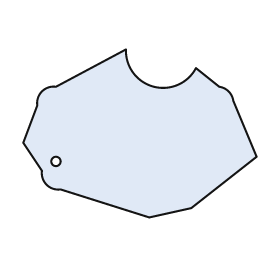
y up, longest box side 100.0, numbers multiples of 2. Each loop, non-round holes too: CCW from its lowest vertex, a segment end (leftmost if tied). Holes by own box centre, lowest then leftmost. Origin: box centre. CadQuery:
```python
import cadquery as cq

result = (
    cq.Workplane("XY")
    .moveTo(4.0, -36.0)
    .lineTo(22.0, -32.0)
    .lineTo(50.0, -10.0)
    .lineTo(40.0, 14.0)
    .threePointArc((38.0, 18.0), (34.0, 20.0))
    .lineTo(24.0, 28.0)
    .threePointArc((6.0, 20.0), (-6.0, 36.0))
    .lineTo(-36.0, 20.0)
    .threePointArc((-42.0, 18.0), (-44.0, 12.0))
    .lineTo(-50.0, -4.0)
    .lineTo(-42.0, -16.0)
    .threePointArc((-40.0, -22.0), (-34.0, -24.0))
    .close()
    .moveTo(-36.0, -12.0)
    .circle(2.0)
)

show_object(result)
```